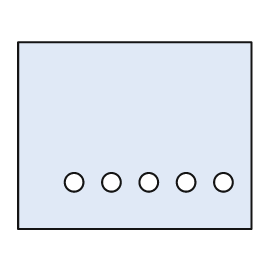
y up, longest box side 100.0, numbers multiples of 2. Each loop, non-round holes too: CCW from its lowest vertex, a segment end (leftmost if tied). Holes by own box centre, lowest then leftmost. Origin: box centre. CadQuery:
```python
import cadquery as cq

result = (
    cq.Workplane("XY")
    .moveTo(-50.0, -40.0)
    .lineTo(50.0, -40.0)
    .lineTo(50.0, 40.0)
    .lineTo(-50.0, 40.0)
    .close()
    .moveTo(-26.0, -20.0)
    .circle(4.0)
    .moveTo(-10.0, -20.0)
    .circle(4.0)
    .moveTo(6.0, -20.0)
    .circle(4.0)
    .moveTo(22.0, -20.0)
    .circle(4.0)
    .moveTo(38.0, -20.0)
    .circle(4.0)
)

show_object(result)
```